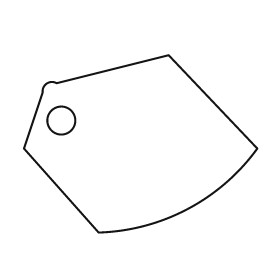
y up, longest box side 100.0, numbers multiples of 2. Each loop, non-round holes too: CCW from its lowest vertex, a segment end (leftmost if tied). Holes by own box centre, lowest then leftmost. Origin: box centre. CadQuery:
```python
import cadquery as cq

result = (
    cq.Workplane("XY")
    .moveTo(-18.0, -38.0)
    .threePointArc((20.0, -28.0), (50.0, -2.0))
    .lineTo(12.0, 38.0)
    .lineTo(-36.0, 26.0)
    .threePointArc((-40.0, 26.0), (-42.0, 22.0))
    .lineTo(-50.0, -2.0)
    .close()
    .moveTo(-34.0, 10.0)
    .circle(6.0)
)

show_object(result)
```